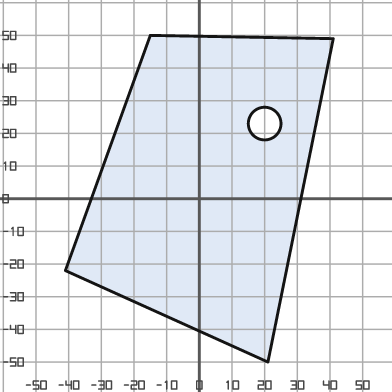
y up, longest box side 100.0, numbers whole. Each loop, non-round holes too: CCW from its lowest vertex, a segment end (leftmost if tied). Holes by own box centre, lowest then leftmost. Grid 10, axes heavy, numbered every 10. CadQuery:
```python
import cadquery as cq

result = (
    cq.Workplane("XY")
    .moveTo(21.0, -50.0)
    .lineTo(41.0, 49.0)
    .lineTo(-15.0, 50.0)
    .lineTo(-41.0, -22.0)
    .close()
    .moveTo(20.0, 23.0)
    .circle(5.0)
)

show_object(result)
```